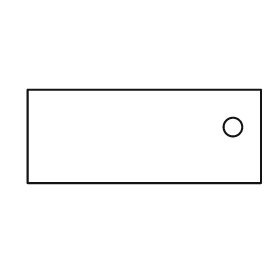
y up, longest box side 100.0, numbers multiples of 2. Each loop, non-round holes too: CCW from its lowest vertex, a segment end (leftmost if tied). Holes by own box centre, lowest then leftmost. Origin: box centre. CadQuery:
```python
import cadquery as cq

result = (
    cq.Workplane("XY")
    .moveTo(-50.0, -20.0)
    .lineTo(50.0, -20.0)
    .lineTo(50.0, 20.0)
    .lineTo(-50.0, 20.0)
    .close()
    .moveTo(38.0, 4.0)
    .circle(4.0)
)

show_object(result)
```